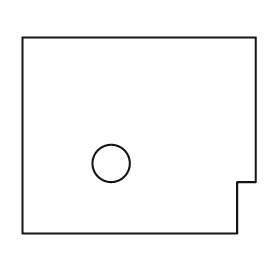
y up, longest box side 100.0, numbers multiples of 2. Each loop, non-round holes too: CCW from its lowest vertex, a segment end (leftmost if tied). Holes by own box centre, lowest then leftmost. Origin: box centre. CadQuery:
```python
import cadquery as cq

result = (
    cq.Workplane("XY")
    .moveTo(-50.0, -42.0)
    .lineTo(42.0, -42.0)
    .lineTo(42.0, -20.0)
    .lineTo(50.0, -20.0)
    .lineTo(50.0, 42.0)
    .lineTo(-50.0, 42.0)
    .close()
    .moveTo(-12.0, -12.0)
    .circle(8.0)
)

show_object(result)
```